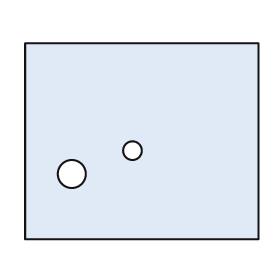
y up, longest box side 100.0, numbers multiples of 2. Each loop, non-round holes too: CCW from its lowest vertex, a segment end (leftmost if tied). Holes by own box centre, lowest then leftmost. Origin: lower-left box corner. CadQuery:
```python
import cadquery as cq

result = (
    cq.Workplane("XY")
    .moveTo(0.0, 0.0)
    .lineTo(100.0, 0.0)
    .lineTo(100.0, 84.0)
    .lineTo(0.0, 84.0)
    .close()
    .moveTo(20.0, 28.0)
    .circle(6.0)
    .moveTo(46.0, 38.0)
    .circle(4.0)
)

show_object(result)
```